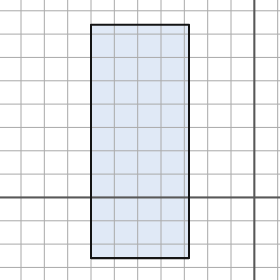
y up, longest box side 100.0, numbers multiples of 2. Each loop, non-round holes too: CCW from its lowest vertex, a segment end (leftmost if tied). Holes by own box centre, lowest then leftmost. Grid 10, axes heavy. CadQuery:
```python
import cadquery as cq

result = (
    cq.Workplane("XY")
    .moveTo(-70.0, -26.0)
    .lineTo(-28.0, -26.0)
    .lineTo(-28.0, 74.0)
    .lineTo(-70.0, 74.0)
    .close()
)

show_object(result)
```